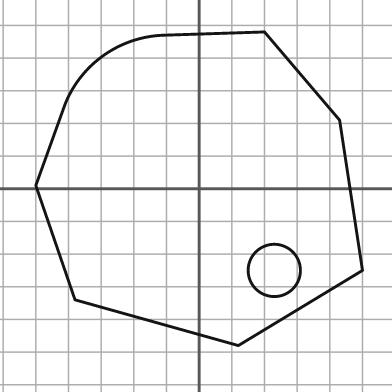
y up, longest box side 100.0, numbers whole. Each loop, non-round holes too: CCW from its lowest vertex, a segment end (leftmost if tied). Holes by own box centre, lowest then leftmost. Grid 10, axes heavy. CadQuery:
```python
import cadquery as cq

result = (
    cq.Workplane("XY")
    .moveTo(12.0, -48.0)
    .lineTo(50.0, -25.0)
    .lineTo(43.0, 21.0)
    .lineTo(20.0, 48.0)
    .lineTo(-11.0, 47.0)
    .threePointArc((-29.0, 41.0), (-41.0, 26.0))
    .lineTo(-50.0, 1.0)
    .lineTo(-38.0, -34.0)
    .close()
    .moveTo(23.0, -25.0)
    .circle(8.0)
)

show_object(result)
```